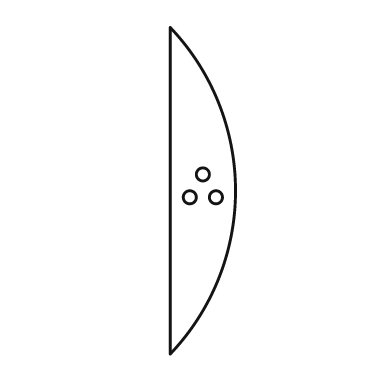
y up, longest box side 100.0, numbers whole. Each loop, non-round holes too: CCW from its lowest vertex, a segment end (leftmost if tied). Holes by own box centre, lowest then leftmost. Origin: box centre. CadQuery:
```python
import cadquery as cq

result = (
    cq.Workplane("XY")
    .moveTo(-10.0, -50.0)
    .threePointArc((10.0, 0.0), (-10.0, 50.0))
    .close()
    .moveTo(-4.0, -2.0)
    .circle(2.0)
    .moveTo(4.0, -2.0)
    .circle(2.0)
    .moveTo(0.0, 5.0)
    .circle(2.0)
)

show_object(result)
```